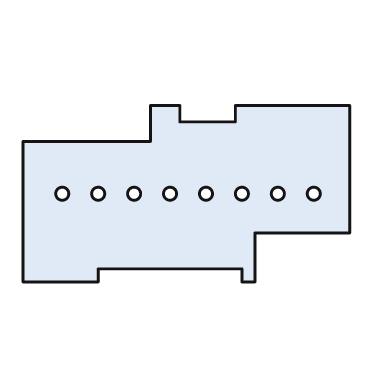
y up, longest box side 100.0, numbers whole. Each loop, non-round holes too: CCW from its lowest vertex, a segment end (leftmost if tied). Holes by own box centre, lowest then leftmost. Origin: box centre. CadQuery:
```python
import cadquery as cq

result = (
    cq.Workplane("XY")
    .moveTo(-50.0, -27.0)
    .lineTo(-27.0, -27.0)
    .lineTo(-27.0, -23.0)
    .lineTo(17.0, -23.0)
    .lineTo(17.0, -27.0)
    .lineTo(21.0, -27.0)
    .lineTo(21.0, -12.0)
    .lineTo(50.0, -12.0)
    .lineTo(50.0, 27.0)
    .lineTo(15.0, 27.0)
    .lineTo(15.0, 22.0)
    .lineTo(-2.0, 22.0)
    .lineTo(-2.0, 27.0)
    .lineTo(-11.0, 27.0)
    .lineTo(-11.0, 16.0)
    .lineTo(-50.0, 16.0)
    .close()
    .moveTo(-38.0, 0.0)
    .circle(2.0)
    .moveTo(-27.0, 0.0)
    .circle(2.0)
    .moveTo(-16.0, 0.0)
    .circle(2.0)
    .moveTo(-5.0, 0.0)
    .circle(2.0)
    .moveTo(6.0, 0.0)
    .circle(2.0)
    .moveTo(17.0, 0.0)
    .circle(2.0)
    .moveTo(28.0, 0.0)
    .circle(2.0)
    .moveTo(39.0, 0.0)
    .circle(2.0)
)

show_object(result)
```